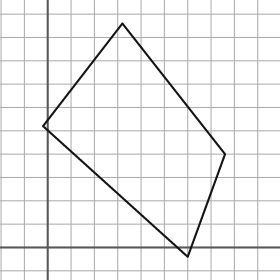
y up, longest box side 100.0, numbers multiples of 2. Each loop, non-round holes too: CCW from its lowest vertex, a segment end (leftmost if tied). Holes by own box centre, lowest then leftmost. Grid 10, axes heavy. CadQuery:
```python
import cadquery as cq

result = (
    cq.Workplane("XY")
    .moveTo(60.0, -4.0)
    .lineTo(76.0, 40.0)
    .lineTo(32.0, 96.0)
    .lineTo(-2.0, 52.0)
    .close()
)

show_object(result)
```